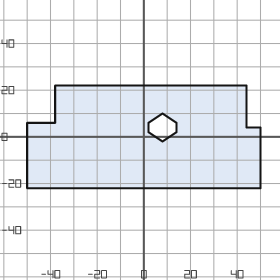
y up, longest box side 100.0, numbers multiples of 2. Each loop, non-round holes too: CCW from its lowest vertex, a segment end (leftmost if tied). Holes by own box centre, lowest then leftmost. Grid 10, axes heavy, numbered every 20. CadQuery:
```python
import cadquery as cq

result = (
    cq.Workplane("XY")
    .moveTo(-50.0, -22.0)
    .lineTo(50.0, -22.0)
    .lineTo(50.0, 4.0)
    .lineTo(44.0, 4.0)
    .lineTo(44.0, 22.0)
    .lineTo(-38.0, 22.0)
    .lineTo(-38.0, 6.0)
    .lineTo(-50.0, 6.0)
    .close()
    .moveTo(8.0, -2.0)
    .lineTo(14.0, 2.0)
    .lineTo(14.0, 6.0)
    .lineTo(8.0, 10.0)
    .lineTo(2.0, 6.0)
    .lineTo(2.0, 2.0)
    .close()
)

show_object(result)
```